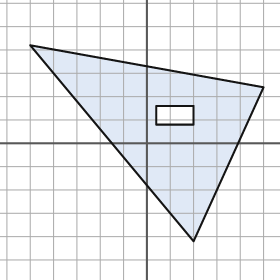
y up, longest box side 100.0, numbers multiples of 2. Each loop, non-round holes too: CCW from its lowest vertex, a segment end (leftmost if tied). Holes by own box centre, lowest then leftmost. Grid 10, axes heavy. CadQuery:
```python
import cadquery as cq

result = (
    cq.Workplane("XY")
    .moveTo(20.0, -42.0)
    .lineTo(50.0, 24.0)
    .lineTo(-50.0, 42.0)
    .close()
    .moveTo(4.0, 8.0)
    .lineTo(20.0, 8.0)
    .lineTo(20.0, 16.0)
    .lineTo(4.0, 16.0)
    .close()
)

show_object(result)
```